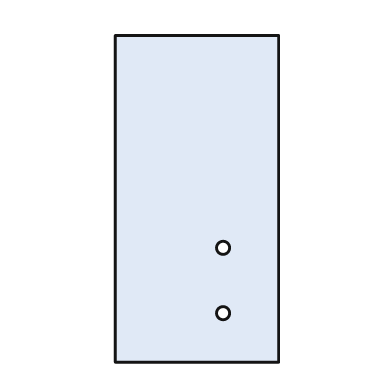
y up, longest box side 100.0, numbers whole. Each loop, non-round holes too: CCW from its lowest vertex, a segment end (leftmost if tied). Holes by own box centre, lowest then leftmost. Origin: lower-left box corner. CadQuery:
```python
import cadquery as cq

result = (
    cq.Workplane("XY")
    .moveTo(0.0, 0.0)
    .lineTo(50.0, 0.0)
    .lineTo(50.0, 100.0)
    .lineTo(0.0, 100.0)
    .close()
    .moveTo(33.0, 15.0)
    .circle(2.0)
    .moveTo(33.0, 35.0)
    .circle(2.0)
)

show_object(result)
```